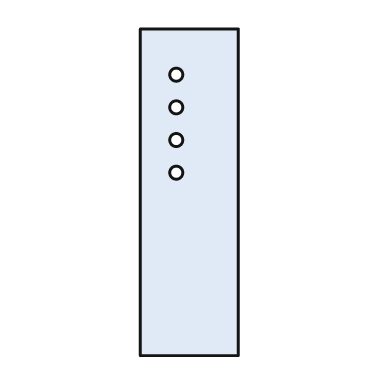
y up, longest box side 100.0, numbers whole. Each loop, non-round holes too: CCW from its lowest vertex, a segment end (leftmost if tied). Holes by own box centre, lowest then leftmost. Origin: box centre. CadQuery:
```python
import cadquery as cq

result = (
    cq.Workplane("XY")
    .moveTo(-15.0, -50.0)
    .lineTo(15.0, -50.0)
    .lineTo(15.0, 50.0)
    .lineTo(-15.0, 50.0)
    .close()
    .moveTo(-4.0, 6.0)
    .circle(2.0)
    .moveTo(-4.0, 16.0)
    .circle(2.0)
    .moveTo(-4.0, 26.0)
    .circle(2.0)
    .moveTo(-4.0, 36.0)
    .circle(2.0)
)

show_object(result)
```